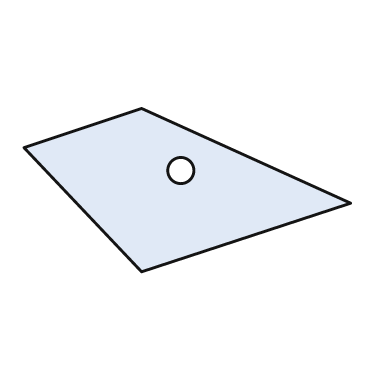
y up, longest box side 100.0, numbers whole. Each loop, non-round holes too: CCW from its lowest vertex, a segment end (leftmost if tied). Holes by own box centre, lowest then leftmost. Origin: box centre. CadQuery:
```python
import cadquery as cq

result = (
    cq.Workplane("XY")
    .moveTo(-14.0, -25.0)
    .lineTo(50.0, -4.0)
    .lineTo(-14.0, 25.0)
    .lineTo(-50.0, 13.0)
    .close()
    .moveTo(-2.0, 6.0)
    .circle(4.0)
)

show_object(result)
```